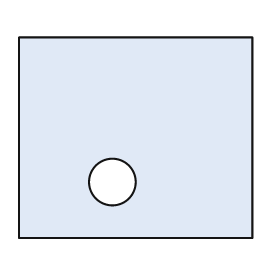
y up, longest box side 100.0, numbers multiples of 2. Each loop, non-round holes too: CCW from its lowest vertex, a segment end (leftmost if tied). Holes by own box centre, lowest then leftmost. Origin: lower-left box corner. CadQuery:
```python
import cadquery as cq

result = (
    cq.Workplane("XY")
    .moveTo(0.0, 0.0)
    .lineTo(100.0, 0.0)
    .lineTo(100.0, 86.0)
    .lineTo(0.0, 86.0)
    .close()
    .moveTo(40.0, 24.0)
    .circle(10.0)
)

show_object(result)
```